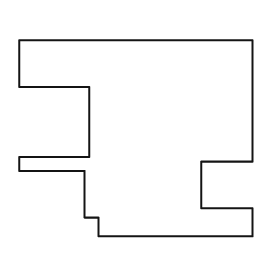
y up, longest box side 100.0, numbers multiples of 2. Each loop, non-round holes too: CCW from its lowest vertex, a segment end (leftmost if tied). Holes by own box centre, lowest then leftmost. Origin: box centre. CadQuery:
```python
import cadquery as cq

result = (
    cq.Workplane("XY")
    .moveTo(-16.0, -42.0)
    .lineTo(50.0, -42.0)
    .lineTo(50.0, -30.0)
    .lineTo(28.0, -30.0)
    .lineTo(28.0, -10.0)
    .lineTo(50.0, -10.0)
    .lineTo(50.0, 42.0)
    .lineTo(-50.0, 42.0)
    .lineTo(-50.0, 22.0)
    .lineTo(-20.0, 22.0)
    .lineTo(-20.0, -8.0)
    .lineTo(-50.0, -8.0)
    .lineTo(-50.0, -14.0)
    .lineTo(-22.0, -14.0)
    .lineTo(-22.0, -34.0)
    .lineTo(-16.0, -34.0)
    .close()
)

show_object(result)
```